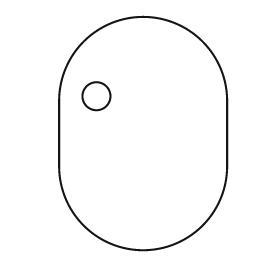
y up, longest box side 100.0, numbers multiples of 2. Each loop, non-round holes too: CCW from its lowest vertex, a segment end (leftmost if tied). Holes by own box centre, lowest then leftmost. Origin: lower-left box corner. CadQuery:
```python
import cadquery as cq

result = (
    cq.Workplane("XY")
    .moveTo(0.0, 36.0)
    .threePointArc((36.0, 0.0), (72.0, 36.0))
    .lineTo(72.0, 64.0)
    .threePointArc((36.0, 100.0), (0.0, 64.0))
    .close()
    .moveTo(16.0, 66.0)
    .circle(6.0)
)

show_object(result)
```